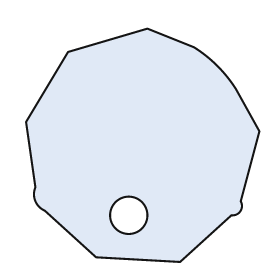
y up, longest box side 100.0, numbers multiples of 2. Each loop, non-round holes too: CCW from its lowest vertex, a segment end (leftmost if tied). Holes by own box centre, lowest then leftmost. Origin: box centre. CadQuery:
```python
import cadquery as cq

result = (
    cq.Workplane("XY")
    .moveTo(16.0, -50.0)
    .lineTo(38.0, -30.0)
    .threePointArc((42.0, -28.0), (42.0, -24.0))
    .lineTo(50.0, 6.0)
    .lineTo(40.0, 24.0)
    .threePointArc((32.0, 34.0), (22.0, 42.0))
    .lineTo(2.0, 50.0)
    .lineTo(-32.0, 40.0)
    .lineTo(-50.0, 10.0)
    .lineTo(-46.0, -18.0)
    .threePointArc((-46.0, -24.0), (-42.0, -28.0))
    .lineTo(-20.0, -48.0)
    .close()
    .moveTo(-6.0, -30.0)
    .circle(8.0)
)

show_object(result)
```